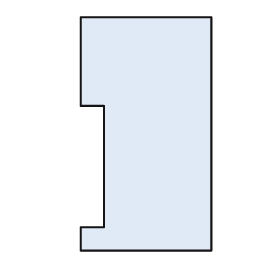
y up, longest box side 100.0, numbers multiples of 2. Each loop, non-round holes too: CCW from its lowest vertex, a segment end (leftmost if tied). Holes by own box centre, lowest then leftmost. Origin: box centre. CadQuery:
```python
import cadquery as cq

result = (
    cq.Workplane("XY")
    .moveTo(-28.0, -50.0)
    .lineTo(28.0, -50.0)
    .lineTo(28.0, 50.0)
    .lineTo(-28.0, 50.0)
    .lineTo(-28.0, 12.0)
    .lineTo(-18.0, 12.0)
    .lineTo(-18.0, -40.0)
    .lineTo(-28.0, -40.0)
    .close()
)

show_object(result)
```